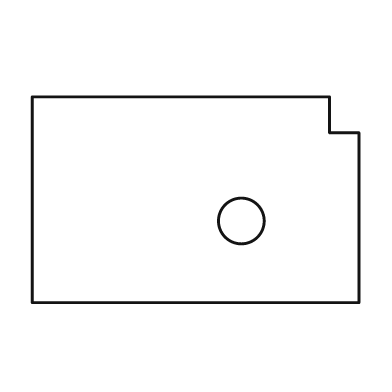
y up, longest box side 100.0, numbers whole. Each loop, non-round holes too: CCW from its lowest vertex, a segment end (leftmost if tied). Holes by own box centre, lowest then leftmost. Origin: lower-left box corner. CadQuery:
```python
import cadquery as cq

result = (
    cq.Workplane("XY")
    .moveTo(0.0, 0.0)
    .lineTo(100.0, 0.0)
    .lineTo(100.0, 52.0)
    .lineTo(91.0, 52.0)
    .lineTo(91.0, 63.0)
    .lineTo(0.0, 63.0)
    .close()
    .moveTo(64.0, 25.0)
    .circle(7.0)
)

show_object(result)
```